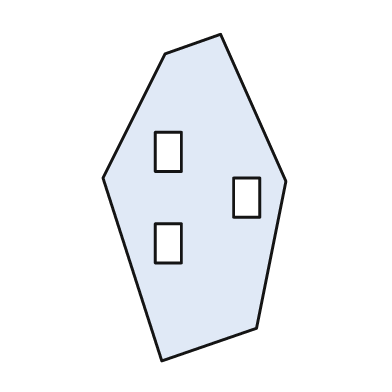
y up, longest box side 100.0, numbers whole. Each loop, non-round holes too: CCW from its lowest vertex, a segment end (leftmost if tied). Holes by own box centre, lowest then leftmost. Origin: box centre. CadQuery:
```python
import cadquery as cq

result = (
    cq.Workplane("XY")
    .moveTo(-10.0, -50.0)
    .lineTo(19.0, -40.0)
    .lineTo(28.0, 5.0)
    .lineTo(8.0, 50.0)
    .lineTo(-9.0, 44.0)
    .lineTo(-28.0, 6.0)
    .close()
    .moveTo(-12.0, -20.0)
    .lineTo(-4.0, -20.0)
    .lineTo(-4.0, -8.0)
    .lineTo(-12.0, -8.0)
    .close()
    .moveTo(12.0, -6.0)
    .lineTo(20.0, -6.0)
    .lineTo(20.0, 6.0)
    .lineTo(12.0, 6.0)
    .close()
    .moveTo(-12.0, 8.0)
    .lineTo(-4.0, 8.0)
    .lineTo(-4.0, 20.0)
    .lineTo(-12.0, 20.0)
    .close()
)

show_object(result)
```